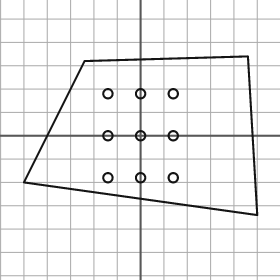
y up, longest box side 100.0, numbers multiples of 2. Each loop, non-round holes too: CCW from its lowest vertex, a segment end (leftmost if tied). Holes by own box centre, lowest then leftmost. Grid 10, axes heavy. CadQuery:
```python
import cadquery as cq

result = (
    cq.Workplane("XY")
    .moveTo(50.0, -34.0)
    .lineTo(46.0, 34.0)
    .lineTo(-24.0, 32.0)
    .lineTo(-50.0, -20.0)
    .close()
    .moveTo(-14.0, -18.0)
    .circle(2.0)
    .moveTo(0.0, -18.0)
    .circle(2.0)
    .moveTo(14.0, -18.0)
    .circle(2.0)
    .moveTo(-14.0, 0.0)
    .circle(2.0)
    .moveTo(0.0, 0.0)
    .circle(2.0)
    .moveTo(14.0, 0.0)
    .circle(2.0)
    .moveTo(-14.0, 18.0)
    .circle(2.0)
    .moveTo(0.0, 18.0)
    .circle(2.0)
    .moveTo(14.0, 18.0)
    .circle(2.0)
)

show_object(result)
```